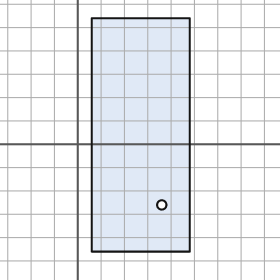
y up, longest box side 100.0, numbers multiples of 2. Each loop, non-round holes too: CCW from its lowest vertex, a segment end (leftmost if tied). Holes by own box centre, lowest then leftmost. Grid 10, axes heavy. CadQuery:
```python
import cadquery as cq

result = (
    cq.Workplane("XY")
    .moveTo(6.0, -46.0)
    .lineTo(48.0, -46.0)
    .lineTo(48.0, 54.0)
    .lineTo(6.0, 54.0)
    .close()
    .moveTo(36.0, -26.0)
    .circle(2.0)
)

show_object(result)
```